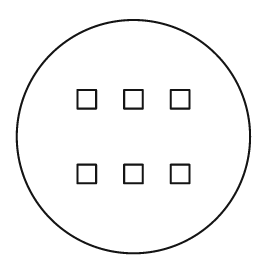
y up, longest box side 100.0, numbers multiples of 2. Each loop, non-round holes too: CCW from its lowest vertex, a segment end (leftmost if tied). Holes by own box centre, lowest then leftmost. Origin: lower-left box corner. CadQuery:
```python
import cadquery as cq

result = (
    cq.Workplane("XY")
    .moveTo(50.0, 50.0)
    .circle(50.0)
    .moveTo(26.0, 30.0)
    .lineTo(34.0, 30.0)
    .lineTo(34.0, 38.0)
    .lineTo(26.0, 38.0)
    .close()
    .moveTo(46.0, 30.0)
    .lineTo(54.0, 30.0)
    .lineTo(54.0, 38.0)
    .lineTo(46.0, 38.0)
    .close()
    .moveTo(66.0, 30.0)
    .lineTo(74.0, 30.0)
    .lineTo(74.0, 38.0)
    .lineTo(66.0, 38.0)
    .close()
    .moveTo(26.0, 62.0)
    .lineTo(34.0, 62.0)
    .lineTo(34.0, 70.0)
    .lineTo(26.0, 70.0)
    .close()
    .moveTo(46.0, 62.0)
    .lineTo(54.0, 62.0)
    .lineTo(54.0, 70.0)
    .lineTo(46.0, 70.0)
    .close()
    .moveTo(66.0, 62.0)
    .lineTo(74.0, 62.0)
    .lineTo(74.0, 70.0)
    .lineTo(66.0, 70.0)
    .close()
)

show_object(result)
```